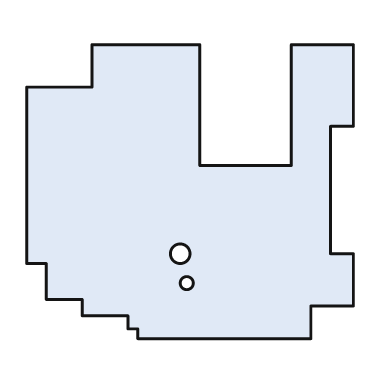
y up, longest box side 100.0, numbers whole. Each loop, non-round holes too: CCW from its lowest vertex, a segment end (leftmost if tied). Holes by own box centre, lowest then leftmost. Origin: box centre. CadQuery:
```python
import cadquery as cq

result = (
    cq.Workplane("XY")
    .moveTo(-16.0, -45.0)
    .lineTo(37.0, -45.0)
    .lineTo(37.0, -35.0)
    .lineTo(50.0, -35.0)
    .lineTo(50.0, -19.0)
    .lineTo(43.0, -19.0)
    .lineTo(43.0, 20.0)
    .lineTo(50.0, 20.0)
    .lineTo(50.0, 45.0)
    .lineTo(31.0, 45.0)
    .lineTo(31.0, 8.0)
    .lineTo(3.0, 8.0)
    .lineTo(3.0, 45.0)
    .lineTo(-30.0, 45.0)
    .lineTo(-30.0, 32.0)
    .lineTo(-50.0, 32.0)
    .lineTo(-50.0, -22.0)
    .lineTo(-44.0, -22.0)
    .lineTo(-44.0, -33.0)
    .lineTo(-33.0, -33.0)
    .lineTo(-33.0, -38.0)
    .lineTo(-19.0, -38.0)
    .lineTo(-19.0, -42.0)
    .lineTo(-16.0, -42.0)
    .close()
    .moveTo(-1.0, -28.0)
    .circle(2.0)
    .moveTo(-3.0, -19.0)
    .circle(3.0)
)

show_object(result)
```